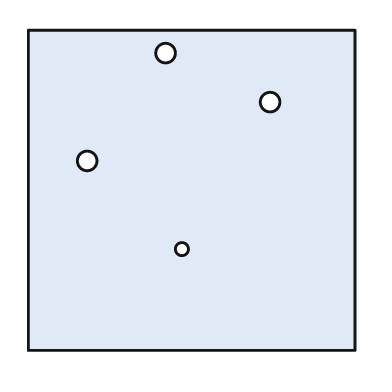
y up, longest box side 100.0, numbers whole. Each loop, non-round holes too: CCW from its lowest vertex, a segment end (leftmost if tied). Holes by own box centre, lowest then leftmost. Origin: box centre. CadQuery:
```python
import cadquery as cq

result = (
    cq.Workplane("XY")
    .moveTo(-50.0, -49.0)
    .lineTo(50.0, -49.0)
    .lineTo(50.0, 49.0)
    .lineTo(-50.0, 49.0)
    .close()
    .moveTo(-3.0, -18.0)
    .circle(2.0)
    .moveTo(-32.0, 9.0)
    .circle(3.0)
    .moveTo(24.0, 27.0)
    .circle(3.0)
    .moveTo(-8.0, 42.0)
    .circle(3.0)
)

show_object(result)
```